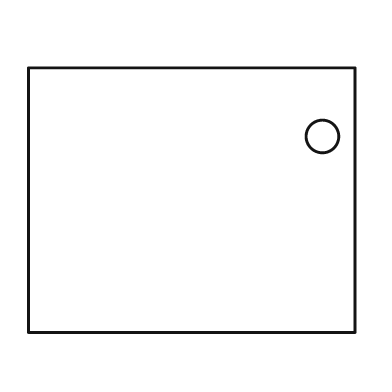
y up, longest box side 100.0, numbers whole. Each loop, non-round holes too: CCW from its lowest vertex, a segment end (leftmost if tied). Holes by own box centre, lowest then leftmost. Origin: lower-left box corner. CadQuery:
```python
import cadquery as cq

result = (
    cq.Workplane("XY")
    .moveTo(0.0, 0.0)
    .lineTo(100.0, 0.0)
    .lineTo(100.0, 81.0)
    .lineTo(0.0, 81.0)
    .close()
    .moveTo(90.0, 60.0)
    .circle(5.0)
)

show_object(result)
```